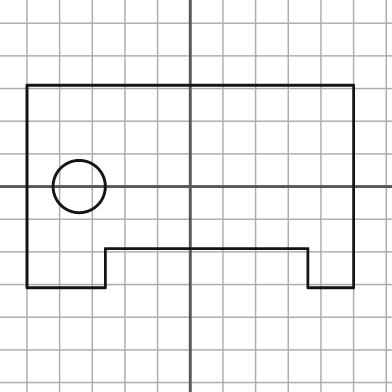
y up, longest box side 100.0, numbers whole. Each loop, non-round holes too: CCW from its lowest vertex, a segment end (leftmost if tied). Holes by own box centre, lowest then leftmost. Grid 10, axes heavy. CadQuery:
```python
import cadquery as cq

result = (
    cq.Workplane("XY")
    .moveTo(-50.0, -31.0)
    .lineTo(-26.0, -31.0)
    .lineTo(-26.0, -19.0)
    .lineTo(36.0, -19.0)
    .lineTo(36.0, -31.0)
    .lineTo(50.0, -31.0)
    .lineTo(50.0, 31.0)
    .lineTo(-50.0, 31.0)
    .close()
    .moveTo(-34.0, 0.0)
    .circle(8.0)
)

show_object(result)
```